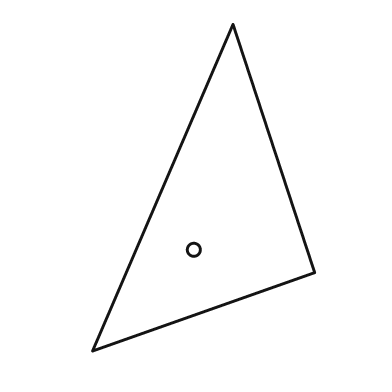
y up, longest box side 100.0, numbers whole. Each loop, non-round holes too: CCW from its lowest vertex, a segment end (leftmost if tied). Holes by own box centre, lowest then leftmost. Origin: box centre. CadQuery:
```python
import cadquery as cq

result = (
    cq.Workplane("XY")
    .moveTo(-34.0, -50.0)
    .lineTo(34.0, -26.0)
    .lineTo(9.0, 50.0)
    .close()
    .moveTo(-3.0, -19.0)
    .circle(2.0)
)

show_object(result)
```